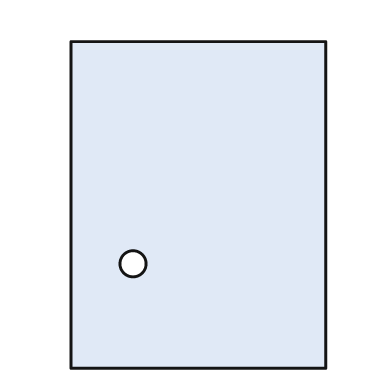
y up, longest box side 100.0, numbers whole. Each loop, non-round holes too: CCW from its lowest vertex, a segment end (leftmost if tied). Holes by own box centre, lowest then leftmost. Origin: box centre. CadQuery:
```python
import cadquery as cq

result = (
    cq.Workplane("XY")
    .moveTo(-39.0, -50.0)
    .lineTo(39.0, -50.0)
    .lineTo(39.0, 50.0)
    .lineTo(-39.0, 50.0)
    .close()
    .moveTo(-20.0, -18.0)
    .circle(4.0)
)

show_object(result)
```